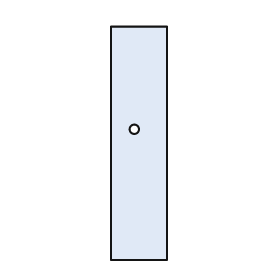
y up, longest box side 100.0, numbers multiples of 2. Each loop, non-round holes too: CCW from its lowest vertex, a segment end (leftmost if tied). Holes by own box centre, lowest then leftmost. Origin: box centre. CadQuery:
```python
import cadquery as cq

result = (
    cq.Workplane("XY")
    .moveTo(-12.0, -50.0)
    .lineTo(12.0, -50.0)
    .lineTo(12.0, 50.0)
    .lineTo(-12.0, 50.0)
    .close()
    .moveTo(-2.0, 6.0)
    .circle(2.0)
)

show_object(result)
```